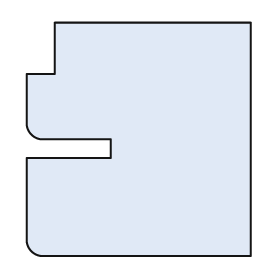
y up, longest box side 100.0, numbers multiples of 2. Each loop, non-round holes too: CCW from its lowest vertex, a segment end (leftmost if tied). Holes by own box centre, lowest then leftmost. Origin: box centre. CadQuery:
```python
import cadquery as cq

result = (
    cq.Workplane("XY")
    .moveTo(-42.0, -50.0)
    .lineTo(48.0, -50.0)
    .lineTo(48.0, 50.0)
    .lineTo(-36.0, 50.0)
    .lineTo(-36.0, 28.0)
    .lineTo(-48.0, 28.0)
    .lineTo(-48.0, 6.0)
    .threePointArc((-46.0, 2.0), (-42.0, 0.0))
    .lineTo(-12.0, 0.0)
    .lineTo(-12.0, -8.0)
    .lineTo(-48.0, -8.0)
    .lineTo(-48.0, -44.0)
    .threePointArc((-46.0, -48.0), (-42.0, -50.0))
    .close()
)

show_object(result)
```